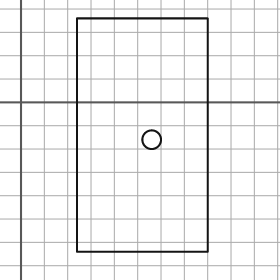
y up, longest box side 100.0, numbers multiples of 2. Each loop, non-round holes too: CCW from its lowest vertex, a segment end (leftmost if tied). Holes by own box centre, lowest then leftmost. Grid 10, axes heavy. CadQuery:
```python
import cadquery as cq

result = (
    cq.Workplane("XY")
    .moveTo(24.0, -64.0)
    .lineTo(80.0, -64.0)
    .lineTo(80.0, 36.0)
    .lineTo(24.0, 36.0)
    .close()
    .moveTo(56.0, -16.0)
    .circle(4.0)
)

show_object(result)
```